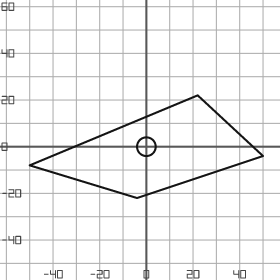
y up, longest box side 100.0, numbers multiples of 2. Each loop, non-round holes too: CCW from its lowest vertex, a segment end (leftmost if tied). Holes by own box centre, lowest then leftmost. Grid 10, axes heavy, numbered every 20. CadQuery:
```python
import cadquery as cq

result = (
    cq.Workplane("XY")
    .moveTo(-4.0, -22.0)
    .lineTo(50.0, -4.0)
    .lineTo(22.0, 22.0)
    .lineTo(-50.0, -8.0)
    .close()
    .moveTo(0.0, 0.0)
    .circle(4.0)
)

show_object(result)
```